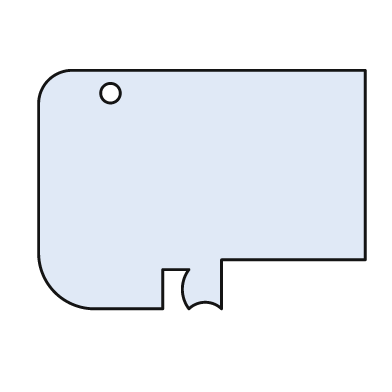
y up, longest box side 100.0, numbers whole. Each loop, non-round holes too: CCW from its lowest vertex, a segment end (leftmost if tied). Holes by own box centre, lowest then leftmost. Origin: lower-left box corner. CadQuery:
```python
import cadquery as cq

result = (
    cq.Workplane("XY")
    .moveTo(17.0, 0.0)
    .lineTo(38.0, 0.0)
    .lineTo(38.0, 12.0)
    .lineTo(46.0, 12.0)
    .threePointArc((44.0, 6.0), (46.0, 0.0))
    .threePointArc((51.0, 2.0), (56.0, 0.0))
    .lineTo(56.0, 15.0)
    .lineTo(100.0, 15.0)
    .lineTo(100.0, 73.0)
    .lineTo(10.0, 73.0)
    .threePointArc((3.0, 70.0), (0.0, 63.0))
    .lineTo(0.0, 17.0)
    .threePointArc((5.0, 5.0), (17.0, 0.0))
    .close()
    .moveTo(22.0, 66.0)
    .circle(3.0)
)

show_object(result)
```